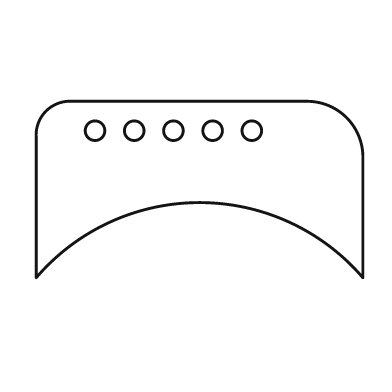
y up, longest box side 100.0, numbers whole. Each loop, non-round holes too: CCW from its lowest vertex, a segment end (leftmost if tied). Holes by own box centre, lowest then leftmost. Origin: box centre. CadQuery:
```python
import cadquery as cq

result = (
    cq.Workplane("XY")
    .moveTo(-50.0, -27.0)
    .threePointArc((0.0, -4.0), (50.0, -27.0))
    .lineTo(50.0, 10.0)
    .threePointArc((45.0, 22.0), (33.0, 27.0))
    .lineTo(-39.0, 27.0)
    .threePointArc((-47.0, 24.0), (-50.0, 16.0))
    .close()
    .moveTo(-32.0, 18.0)
    .circle(3.0)
    .moveTo(-20.0, 18.0)
    .circle(3.0)
    .moveTo(-8.0, 18.0)
    .circle(3.0)
    .moveTo(4.0, 18.0)
    .circle(3.0)
    .moveTo(16.0, 18.0)
    .circle(3.0)
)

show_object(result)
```